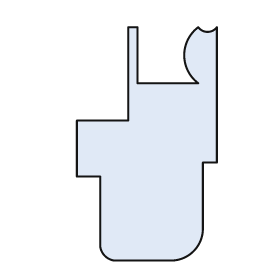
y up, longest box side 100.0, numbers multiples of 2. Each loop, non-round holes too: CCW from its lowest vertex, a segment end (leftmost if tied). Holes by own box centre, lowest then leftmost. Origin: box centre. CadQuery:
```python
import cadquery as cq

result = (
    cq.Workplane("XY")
    .moveTo(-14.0, -50.0)
    .lineTo(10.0, -50.0)
    .threePointArc((20.0, -46.0), (24.0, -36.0))
    .lineTo(24.0, -8.0)
    .lineTo(30.0, -8.0)
    .lineTo(30.0, 50.0)
    .threePointArc((26.0, 48.0), (22.0, 50.0))
    .threePointArc((16.0, 38.0), (22.0, 26.0))
    .lineTo(-4.0, 26.0)
    .lineTo(-4.0, 50.0)
    .lineTo(-8.0, 50.0)
    .lineTo(-8.0, 10.0)
    .lineTo(-30.0, 10.0)
    .lineTo(-30.0, -14.0)
    .lineTo(-20.0, -14.0)
    .lineTo(-20.0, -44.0)
    .threePointArc((-18.0, -48.0), (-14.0, -50.0))
    .close()
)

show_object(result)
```